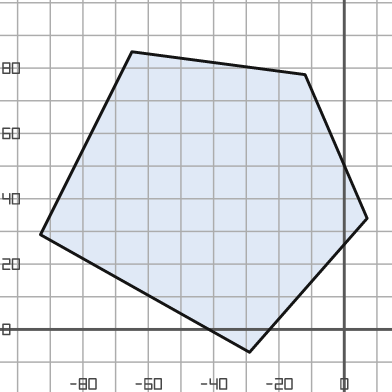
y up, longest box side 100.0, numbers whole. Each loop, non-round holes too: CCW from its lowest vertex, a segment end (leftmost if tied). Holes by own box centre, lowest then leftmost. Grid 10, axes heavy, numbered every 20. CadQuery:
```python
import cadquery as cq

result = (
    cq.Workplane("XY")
    .moveTo(-29.0, -7.0)
    .lineTo(7.0, 34.0)
    .lineTo(-12.0, 78.0)
    .lineTo(-65.0, 85.0)
    .lineTo(-93.0, 29.0)
    .close()
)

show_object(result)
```